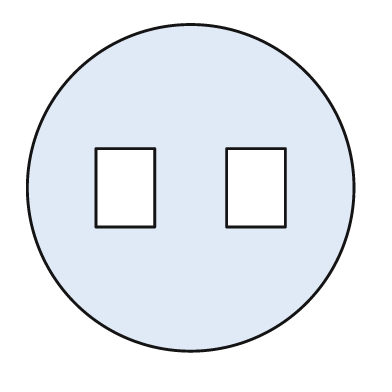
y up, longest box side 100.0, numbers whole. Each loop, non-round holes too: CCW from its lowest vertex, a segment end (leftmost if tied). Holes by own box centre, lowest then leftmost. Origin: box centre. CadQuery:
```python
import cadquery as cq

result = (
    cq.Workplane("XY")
    .moveTo(0.0, 0.0)
    .circle(50.0)
    .moveTo(-29.0, -12.0)
    .lineTo(-11.0, -12.0)
    .lineTo(-11.0, 12.0)
    .lineTo(-29.0, 12.0)
    .close()
    .moveTo(11.0, -12.0)
    .lineTo(29.0, -12.0)
    .lineTo(29.0, 12.0)
    .lineTo(11.0, 12.0)
    .close()
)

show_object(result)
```